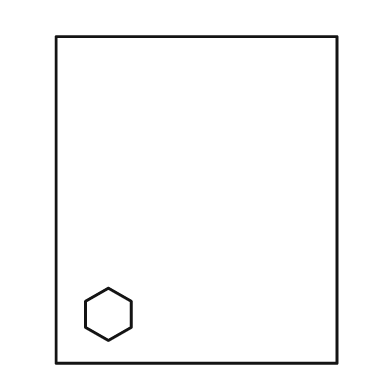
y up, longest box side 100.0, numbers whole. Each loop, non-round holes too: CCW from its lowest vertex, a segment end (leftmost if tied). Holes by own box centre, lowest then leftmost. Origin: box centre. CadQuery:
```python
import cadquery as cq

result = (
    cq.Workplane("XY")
    .moveTo(-43.0, -50.0)
    .lineTo(43.0, -50.0)
    .lineTo(43.0, 50.0)
    .lineTo(-43.0, 50.0)
    .close()
    .moveTo(-27.0, -43.0)
    .lineTo(-20.0, -39.0)
    .lineTo(-20.0, -31.0)
    .lineTo(-27.0, -27.0)
    .lineTo(-34.0, -31.0)
    .lineTo(-34.0, -39.0)
    .close()
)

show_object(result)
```